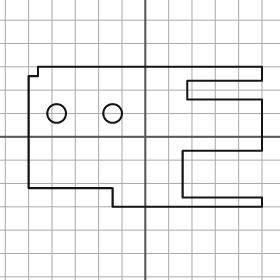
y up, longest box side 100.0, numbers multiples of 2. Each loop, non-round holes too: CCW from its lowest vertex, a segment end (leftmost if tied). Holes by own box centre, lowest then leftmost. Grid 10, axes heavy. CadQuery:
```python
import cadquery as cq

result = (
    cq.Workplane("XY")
    .moveTo(-14.0, -30.0)
    .lineTo(50.0, -30.0)
    .lineTo(50.0, -26.0)
    .lineTo(16.0, -26.0)
    .lineTo(16.0, -6.0)
    .lineTo(50.0, -6.0)
    .lineTo(50.0, 16.0)
    .lineTo(18.0, 16.0)
    .lineTo(18.0, 24.0)
    .lineTo(50.0, 24.0)
    .lineTo(50.0, 30.0)
    .lineTo(-46.0, 30.0)
    .lineTo(-46.0, 26.0)
    .lineTo(-50.0, 26.0)
    .lineTo(-50.0, -22.0)
    .lineTo(-14.0, -22.0)
    .close()
    .moveTo(-38.0, 10.0)
    .circle(4.0)
    .moveTo(-14.0, 10.0)
    .circle(4.0)
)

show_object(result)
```